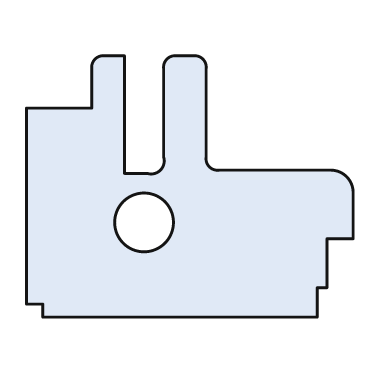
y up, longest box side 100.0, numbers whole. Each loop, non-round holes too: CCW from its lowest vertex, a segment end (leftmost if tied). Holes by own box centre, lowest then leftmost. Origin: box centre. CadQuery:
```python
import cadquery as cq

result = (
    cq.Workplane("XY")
    .moveTo(-45.0, -40.0)
    .lineTo(39.0, -40.0)
    .lineTo(39.0, -31.0)
    .lineTo(42.0, -31.0)
    .lineTo(42.0, -16.0)
    .lineTo(50.0, -16.0)
    .lineTo(50.0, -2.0)
    .threePointArc((48.0, 3.0), (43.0, 5.0))
    .lineTo(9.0, 5.0)
    .threePointArc((6.0, 6.0), (5.0, 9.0))
    .lineTo(5.0, 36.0)
    .threePointArc((4.0, 39.0), (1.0, 40.0))
    .lineTo(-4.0, 40.0)
    .threePointArc((-7.0, 39.0), (-8.0, 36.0))
    .lineTo(-8.0, 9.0)
    .threePointArc((-9.0, 5.0), (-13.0, 4.0))
    .lineTo(-20.0, 4.0)
    .lineTo(-20.0, 40.0)
    .lineTo(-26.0, 40.0)
    .threePointArc((-29.0, 39.0), (-30.0, 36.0))
    .lineTo(-30.0, 24.0)
    .lineTo(-50.0, 24.0)
    .lineTo(-50.0, -36.0)
    .lineTo(-45.0, -36.0)
    .close()
    .moveTo(-14.0, -11.0)
    .circle(9.0)
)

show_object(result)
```